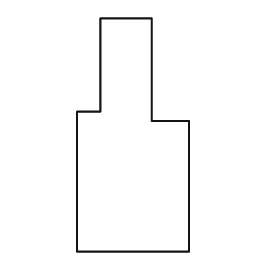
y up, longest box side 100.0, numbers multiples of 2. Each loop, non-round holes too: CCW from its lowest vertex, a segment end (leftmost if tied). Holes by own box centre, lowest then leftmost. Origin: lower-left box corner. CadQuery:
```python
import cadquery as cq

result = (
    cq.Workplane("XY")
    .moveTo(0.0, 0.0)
    .lineTo(48.0, 0.0)
    .lineTo(48.0, 56.0)
    .lineTo(32.0, 56.0)
    .lineTo(32.0, 100.0)
    .lineTo(10.0, 100.0)
    .lineTo(10.0, 60.0)
    .lineTo(0.0, 60.0)
    .close()
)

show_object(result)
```